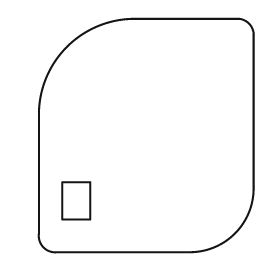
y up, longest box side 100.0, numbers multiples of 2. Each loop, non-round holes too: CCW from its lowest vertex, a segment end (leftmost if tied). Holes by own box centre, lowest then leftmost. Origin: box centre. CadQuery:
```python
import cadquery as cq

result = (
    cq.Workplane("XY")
    .moveTo(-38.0, -50.0)
    .lineTo(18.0, -50.0)
    .threePointArc((38.0, -42.0), (46.0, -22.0))
    .lineTo(46.0, 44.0)
    .threePointArc((44.0, 48.0), (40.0, 50.0))
    .lineTo(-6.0, 50.0)
    .threePointArc((-34.0, 38.0), (-46.0, 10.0))
    .lineTo(-46.0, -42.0)
    .threePointArc((-44.0, -48.0), (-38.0, -50.0))
    .close()
    .moveTo(-36.0, -36.0)
    .lineTo(-24.0, -36.0)
    .lineTo(-24.0, -20.0)
    .lineTo(-36.0, -20.0)
    .close()
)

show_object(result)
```